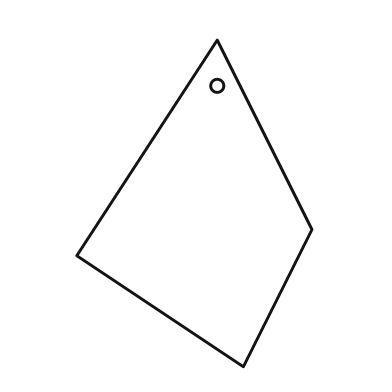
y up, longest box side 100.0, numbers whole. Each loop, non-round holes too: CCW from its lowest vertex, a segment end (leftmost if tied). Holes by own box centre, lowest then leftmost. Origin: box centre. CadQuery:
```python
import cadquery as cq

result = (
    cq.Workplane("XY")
    .moveTo(15.0, -50.0)
    .lineTo(36.0, -8.0)
    .lineTo(7.0, 50.0)
    .lineTo(-36.0, -16.0)
    .close()
    .moveTo(7.0, 36.0)
    .circle(2.0)
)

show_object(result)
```